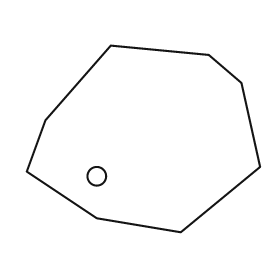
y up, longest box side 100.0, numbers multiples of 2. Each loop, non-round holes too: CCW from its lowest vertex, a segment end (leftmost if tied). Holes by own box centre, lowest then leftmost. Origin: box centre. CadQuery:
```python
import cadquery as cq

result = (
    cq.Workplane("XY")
    .moveTo(16.0, -40.0)
    .lineTo(50.0, -12.0)
    .lineTo(42.0, 24.0)
    .lineTo(28.0, 36.0)
    .lineTo(-14.0, 40.0)
    .lineTo(-42.0, 8.0)
    .lineTo(-50.0, -14.0)
    .lineTo(-20.0, -34.0)
    .close()
    .moveTo(-20.0, -16.0)
    .circle(4.0)
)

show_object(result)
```